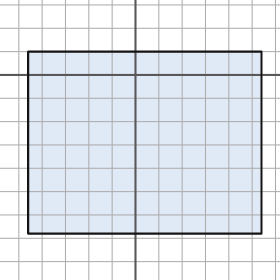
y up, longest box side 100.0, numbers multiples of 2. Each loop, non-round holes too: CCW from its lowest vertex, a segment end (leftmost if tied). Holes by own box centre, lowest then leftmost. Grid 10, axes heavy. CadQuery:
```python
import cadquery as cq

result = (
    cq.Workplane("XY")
    .moveTo(-46.0, -68.0)
    .lineTo(54.0, -68.0)
    .lineTo(54.0, 10.0)
    .lineTo(-46.0, 10.0)
    .close()
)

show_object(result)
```